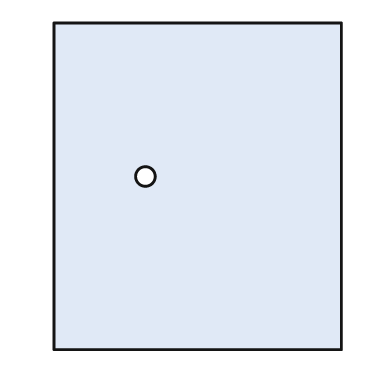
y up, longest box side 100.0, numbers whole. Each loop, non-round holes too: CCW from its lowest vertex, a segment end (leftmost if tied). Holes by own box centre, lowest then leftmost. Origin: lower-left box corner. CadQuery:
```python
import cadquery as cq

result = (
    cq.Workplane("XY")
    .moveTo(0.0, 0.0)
    .lineTo(88.0, 0.0)
    .lineTo(88.0, 100.0)
    .lineTo(0.0, 100.0)
    .close()
    .moveTo(28.0, 53.0)
    .circle(3.0)
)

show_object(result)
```